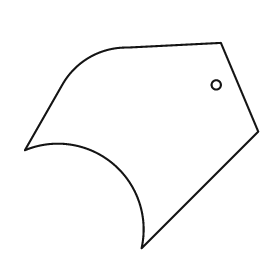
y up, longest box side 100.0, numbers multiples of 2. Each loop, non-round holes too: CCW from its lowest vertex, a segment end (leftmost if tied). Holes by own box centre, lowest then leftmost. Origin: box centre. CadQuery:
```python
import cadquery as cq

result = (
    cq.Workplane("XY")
    .moveTo(0.0, -44.0)
    .lineTo(50.0, 6.0)
    .lineTo(34.0, 44.0)
    .lineTo(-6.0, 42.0)
    .threePointArc((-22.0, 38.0), (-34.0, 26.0))
    .lineTo(-50.0, -2.0)
    .threePointArc((-12.0, -8.0), (0.0, -44.0))
    .close()
    .moveTo(32.0, 26.0)
    .circle(2.0)
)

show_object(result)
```